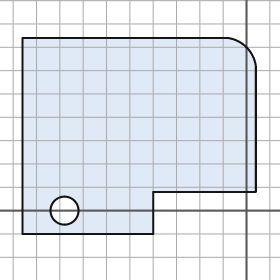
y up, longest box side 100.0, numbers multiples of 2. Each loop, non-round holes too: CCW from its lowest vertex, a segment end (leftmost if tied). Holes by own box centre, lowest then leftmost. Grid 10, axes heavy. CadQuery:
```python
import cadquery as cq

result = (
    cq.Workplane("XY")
    .moveTo(-96.0, -10.0)
    .lineTo(-40.0, -10.0)
    .lineTo(-40.0, 8.0)
    .lineTo(4.0, 8.0)
    .lineTo(4.0, 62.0)
    .threePointArc((0.0, 70.0), (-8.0, 74.0))
    .lineTo(-96.0, 74.0)
    .close()
    .moveTo(-78.0, 0.0)
    .circle(6.0)
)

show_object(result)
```